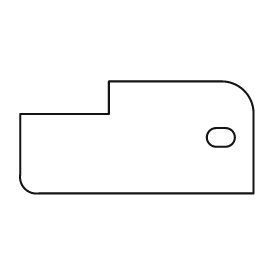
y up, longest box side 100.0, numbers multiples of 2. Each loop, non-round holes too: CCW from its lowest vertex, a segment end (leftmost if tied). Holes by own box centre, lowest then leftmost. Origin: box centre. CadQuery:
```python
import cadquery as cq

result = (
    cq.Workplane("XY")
    .moveTo(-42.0, -24.0)
    .lineTo(50.0, -24.0)
    .lineTo(50.0, 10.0)
    .threePointArc((46.0, 20.0), (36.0, 24.0))
    .lineTo(-12.0, 24.0)
    .lineTo(-12.0, 10.0)
    .lineTo(-50.0, 10.0)
    .lineTo(-50.0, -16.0)
    .threePointArc((-48.0, -22.0), (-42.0, -24.0))
    .close()
    .moveTo(34.0, -4.0)
    .lineTo(38.0, -4.0)
    .threePointArc((42.0, 0.0), (38.0, 4.0))
    .lineTo(34.0, 4.0)
    .threePointArc((30.0, 0.0), (34.0, -4.0))
    .close()
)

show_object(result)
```